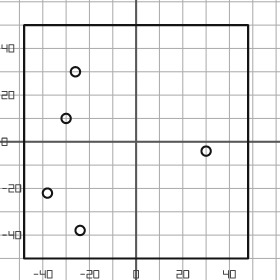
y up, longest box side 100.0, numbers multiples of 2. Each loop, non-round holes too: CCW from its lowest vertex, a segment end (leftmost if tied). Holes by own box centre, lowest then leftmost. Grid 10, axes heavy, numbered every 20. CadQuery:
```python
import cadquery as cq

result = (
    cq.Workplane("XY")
    .moveTo(-48.0, -50.0)
    .lineTo(48.0, -50.0)
    .lineTo(48.0, 50.0)
    .lineTo(-48.0, 50.0)
    .close()
    .moveTo(-24.0, -38.0)
    .circle(2.0)
    .moveTo(-38.0, -22.0)
    .circle(2.0)
    .moveTo(30.0, -4.0)
    .circle(2.0)
    .moveTo(-30.0, 10.0)
    .circle(2.0)
    .moveTo(-26.0, 30.0)
    .circle(2.0)
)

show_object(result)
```